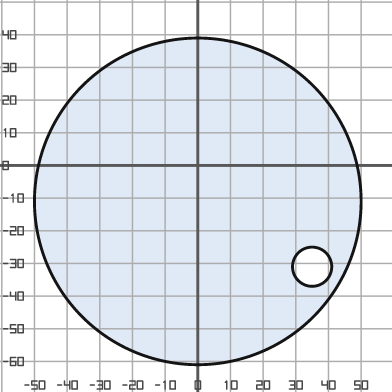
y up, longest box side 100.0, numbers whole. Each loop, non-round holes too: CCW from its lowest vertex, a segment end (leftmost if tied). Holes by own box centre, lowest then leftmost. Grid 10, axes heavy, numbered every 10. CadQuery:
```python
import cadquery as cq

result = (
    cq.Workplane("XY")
    .moveTo(0.0, -11.0)
    .circle(50.0)
    .moveTo(35.0, -31.0)
    .circle(6.0)
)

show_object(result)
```